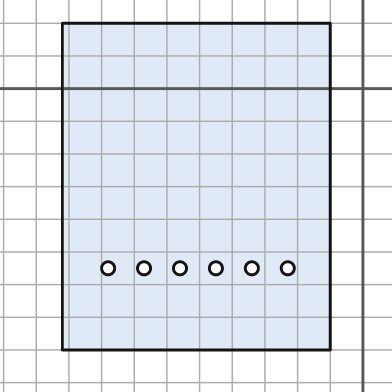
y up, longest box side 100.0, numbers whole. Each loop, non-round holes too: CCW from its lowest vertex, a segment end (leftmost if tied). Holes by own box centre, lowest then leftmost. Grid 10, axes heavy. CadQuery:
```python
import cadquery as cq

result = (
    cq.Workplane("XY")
    .moveTo(-92.0, -80.0)
    .lineTo(-10.0, -80.0)
    .lineTo(-10.0, 20.0)
    .lineTo(-92.0, 20.0)
    .close()
    .moveTo(-78.0, -55.0)
    .circle(2.0)
    .moveTo(-67.0, -55.0)
    .circle(2.0)
    .moveTo(-56.0, -55.0)
    .circle(2.0)
    .moveTo(-45.0, -55.0)
    .circle(2.0)
    .moveTo(-34.0, -55.0)
    .circle(2.0)
    .moveTo(-23.0, -55.0)
    .circle(2.0)
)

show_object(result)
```